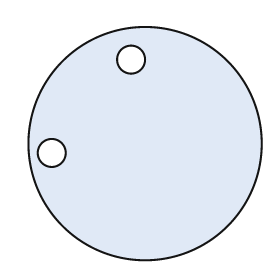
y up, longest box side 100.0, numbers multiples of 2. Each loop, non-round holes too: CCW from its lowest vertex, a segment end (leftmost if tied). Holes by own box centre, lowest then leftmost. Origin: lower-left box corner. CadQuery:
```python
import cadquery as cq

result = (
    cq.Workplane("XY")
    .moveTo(50.0, 50.0)
    .circle(50.0)
    .moveTo(10.0, 46.0)
    .circle(6.0)
    .moveTo(44.0, 86.0)
    .circle(6.0)
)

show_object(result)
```